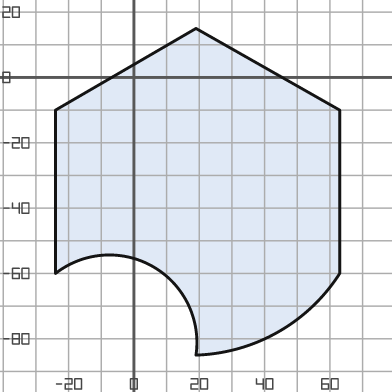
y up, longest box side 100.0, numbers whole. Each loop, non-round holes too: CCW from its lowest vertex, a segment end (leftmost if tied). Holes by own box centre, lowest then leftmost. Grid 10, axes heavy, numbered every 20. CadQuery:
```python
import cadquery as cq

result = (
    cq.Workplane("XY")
    .moveTo(19.0, -85.0)
    .threePointArc((44.0, -78.0), (63.0, -60.0))
    .lineTo(63.0, -10.0)
    .lineTo(19.0, 15.0)
    .lineTo(-24.0, -10.0)
    .lineTo(-24.0, -60.0)
    .threePointArc((6.0, -58.0), (19.0, -85.0))
    .close()
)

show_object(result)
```